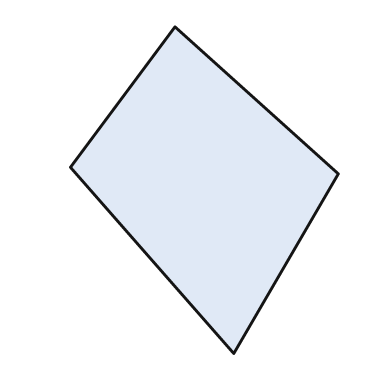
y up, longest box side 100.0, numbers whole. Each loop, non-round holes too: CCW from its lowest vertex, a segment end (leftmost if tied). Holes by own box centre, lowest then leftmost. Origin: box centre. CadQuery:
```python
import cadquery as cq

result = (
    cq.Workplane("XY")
    .moveTo(9.0, -50.0)
    .lineTo(41.0, 5.0)
    .lineTo(-9.0, 50.0)
    .lineTo(-41.0, 7.0)
    .close()
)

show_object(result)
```